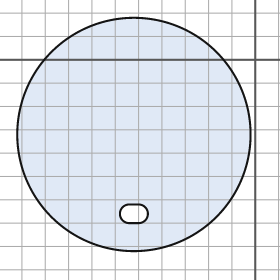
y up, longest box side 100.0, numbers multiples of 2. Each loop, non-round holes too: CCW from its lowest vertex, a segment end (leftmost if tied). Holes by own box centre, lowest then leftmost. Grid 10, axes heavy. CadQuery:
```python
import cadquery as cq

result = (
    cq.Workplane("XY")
    .moveTo(-52.0, -32.0)
    .circle(50.0)
    .moveTo(-54.0, -70.0)
    .lineTo(-50.0, -70.0)
    .threePointArc((-46.0, -66.0), (-50.0, -62.0))
    .lineTo(-54.0, -62.0)
    .threePointArc((-58.0, -66.0), (-54.0, -70.0))
    .close()
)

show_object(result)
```